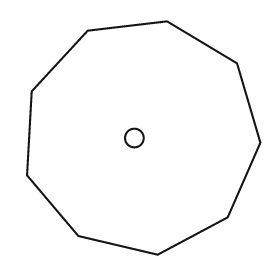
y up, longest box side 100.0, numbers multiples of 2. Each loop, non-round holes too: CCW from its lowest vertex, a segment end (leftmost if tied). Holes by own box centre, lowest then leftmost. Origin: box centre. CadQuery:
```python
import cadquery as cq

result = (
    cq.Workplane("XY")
    .moveTo(6.0, -50.0)
    .lineTo(36.0, -34.0)
    .lineTo(50.0, -2.0)
    .lineTo(40.0, 32.0)
    .lineTo(10.0, 50.0)
    .lineTo(-24.0, 46.0)
    .lineTo(-48.0, 20.0)
    .lineTo(-50.0, -16.0)
    .lineTo(-28.0, -42.0)
    .close()
    .moveTo(-4.0, 0.0)
    .circle(4.0)
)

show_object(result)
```